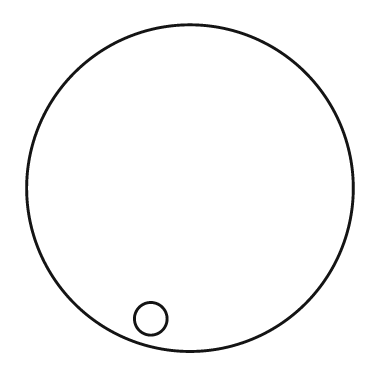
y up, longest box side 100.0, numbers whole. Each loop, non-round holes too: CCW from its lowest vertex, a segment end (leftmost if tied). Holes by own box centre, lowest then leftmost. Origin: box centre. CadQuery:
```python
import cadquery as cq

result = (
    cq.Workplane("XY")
    .moveTo(0.0, 0.0)
    .circle(50.0)
    .moveTo(-12.0, -40.0)
    .circle(5.0)
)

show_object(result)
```